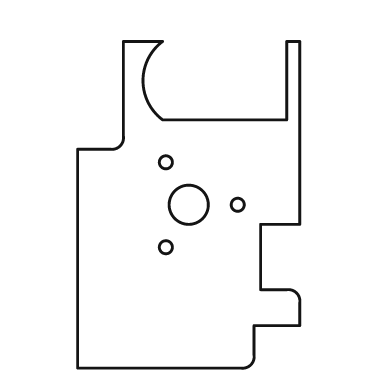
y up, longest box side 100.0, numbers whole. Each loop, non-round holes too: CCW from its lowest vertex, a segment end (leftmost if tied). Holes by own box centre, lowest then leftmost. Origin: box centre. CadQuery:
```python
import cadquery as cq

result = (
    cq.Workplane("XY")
    .moveTo(-34.0, -50.0)
    .lineTo(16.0, -50.0)
    .threePointArc((19.0, -49.0), (20.0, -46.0))
    .lineTo(20.0, -37.0)
    .lineTo(34.0, -37.0)
    .lineTo(34.0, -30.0)
    .threePointArc((33.0, -27.0), (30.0, -26.0))
    .lineTo(22.0, -26.0)
    .lineTo(22.0, -6.0)
    .lineTo(34.0, -6.0)
    .lineTo(34.0, 50.0)
    .lineTo(30.0, 50.0)
    .lineTo(30.0, 26.0)
    .lineTo(-8.0, 26.0)
    .threePointArc((-14.0, 38.0), (-8.0, 50.0))
    .lineTo(-20.0, 50.0)
    .lineTo(-20.0, 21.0)
    .threePointArc((-21.0, 18.0), (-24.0, 17.0))
    .lineTo(-34.0, 17.0)
    .close()
    .moveTo(-7.0, -13.0)
    .circle(2.0)
    .moveTo(0.0, 0.0)
    .circle(6.0)
    .moveTo(15.0, 0.0)
    .circle(2.0)
    .moveTo(-7.0, 13.0)
    .circle(2.0)
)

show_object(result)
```